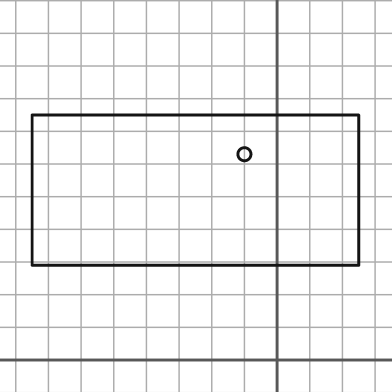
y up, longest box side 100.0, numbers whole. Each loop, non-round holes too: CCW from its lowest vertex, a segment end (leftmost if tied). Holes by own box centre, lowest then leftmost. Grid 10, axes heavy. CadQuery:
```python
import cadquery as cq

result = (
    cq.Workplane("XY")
    .moveTo(-75.0, 29.0)
    .lineTo(25.0, 29.0)
    .lineTo(25.0, 75.0)
    .lineTo(-75.0, 75.0)
    .close()
    .moveTo(-10.0, 63.0)
    .circle(2.0)
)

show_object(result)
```